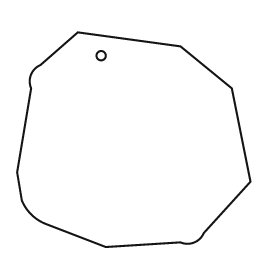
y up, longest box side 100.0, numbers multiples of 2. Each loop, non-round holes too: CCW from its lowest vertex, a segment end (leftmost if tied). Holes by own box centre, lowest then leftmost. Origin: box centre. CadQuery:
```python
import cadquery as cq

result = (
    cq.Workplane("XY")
    .moveTo(-12.0, -46.0)
    .lineTo(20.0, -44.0)
    .threePointArc((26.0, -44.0), (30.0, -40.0))
    .lineTo(50.0, -18.0)
    .lineTo(42.0, 22.0)
    .lineTo(20.0, 40.0)
    .lineTo(-24.0, 46.0)
    .lineTo(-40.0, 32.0)
    .threePointArc((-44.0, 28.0), (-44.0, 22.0))
    .lineTo(-50.0, -14.0)
    .lineTo(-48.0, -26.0)
    .threePointArc((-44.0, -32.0), (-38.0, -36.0))
    .close()
    .moveTo(-14.0, 36.0)
    .circle(2.0)
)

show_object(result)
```